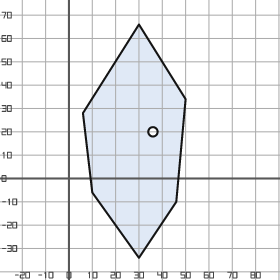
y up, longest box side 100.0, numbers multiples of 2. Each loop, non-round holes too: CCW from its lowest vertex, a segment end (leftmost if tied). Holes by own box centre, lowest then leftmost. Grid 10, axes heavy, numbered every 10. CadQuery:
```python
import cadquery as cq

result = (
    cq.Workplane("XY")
    .moveTo(30.0, -34.0)
    .lineTo(46.0, -10.0)
    .lineTo(50.0, 34.0)
    .lineTo(30.0, 66.0)
    .lineTo(6.0, 28.0)
    .lineTo(10.0, -6.0)
    .close()
    .moveTo(36.0, 20.0)
    .circle(2.0)
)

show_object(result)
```